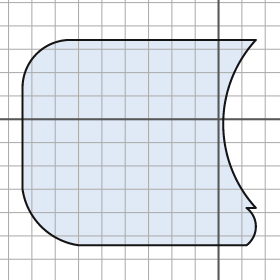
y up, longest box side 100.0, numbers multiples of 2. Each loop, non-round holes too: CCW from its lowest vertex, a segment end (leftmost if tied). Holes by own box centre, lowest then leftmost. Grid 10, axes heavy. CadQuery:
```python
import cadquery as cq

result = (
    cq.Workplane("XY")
    .moveTo(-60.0, -54.0)
    .lineTo(12.0, -54.0)
    .threePointArc((16.0, -46.0), (12.0, -38.0))
    .lineTo(16.0, -38.0)
    .threePointArc((2.0, -2.0), (16.0, 34.0))
    .lineTo(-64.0, 34.0)
    .threePointArc((-78.0, 28.0), (-84.0, 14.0))
    .lineTo(-84.0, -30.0)
    .threePointArc((-76.0, -46.0), (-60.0, -54.0))
    .close()
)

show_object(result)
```